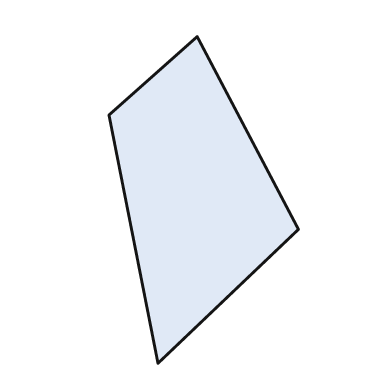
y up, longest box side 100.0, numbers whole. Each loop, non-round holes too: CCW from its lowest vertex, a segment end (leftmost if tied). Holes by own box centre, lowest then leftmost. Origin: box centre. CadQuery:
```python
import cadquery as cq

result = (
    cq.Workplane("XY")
    .moveTo(-14.0, -50.0)
    .lineTo(29.0, -9.0)
    .lineTo(-2.0, 50.0)
    .lineTo(-29.0, 26.0)
    .close()
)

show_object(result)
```